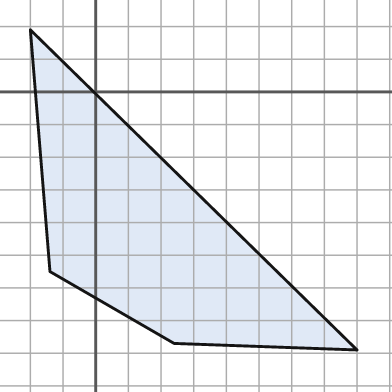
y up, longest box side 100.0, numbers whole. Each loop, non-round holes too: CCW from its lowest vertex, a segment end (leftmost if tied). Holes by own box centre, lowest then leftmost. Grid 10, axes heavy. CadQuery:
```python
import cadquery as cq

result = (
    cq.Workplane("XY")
    .moveTo(80.0, -79.0)
    .lineTo(-20.0, 19.0)
    .lineTo(-14.0, -55.0)
    .lineTo(24.0, -77.0)
    .close()
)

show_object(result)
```